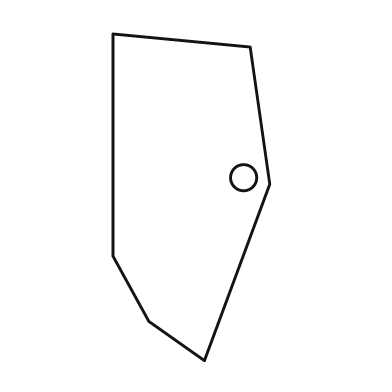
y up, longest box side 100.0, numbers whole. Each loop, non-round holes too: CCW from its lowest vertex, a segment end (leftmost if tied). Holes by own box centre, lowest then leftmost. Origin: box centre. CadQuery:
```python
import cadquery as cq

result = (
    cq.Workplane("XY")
    .moveTo(4.0, -50.0)
    .lineTo(24.0, 4.0)
    .lineTo(18.0, 46.0)
    .lineTo(-24.0, 50.0)
    .lineTo(-24.0, -18.0)
    .lineTo(-13.0, -38.0)
    .close()
    .moveTo(16.0, 6.0)
    .circle(4.0)
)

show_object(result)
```